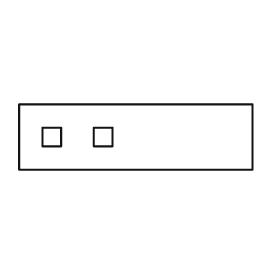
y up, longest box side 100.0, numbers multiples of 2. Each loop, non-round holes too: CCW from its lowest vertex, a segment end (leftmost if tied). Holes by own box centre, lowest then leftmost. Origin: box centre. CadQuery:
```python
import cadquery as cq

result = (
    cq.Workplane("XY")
    .moveTo(-50.0, -14.0)
    .lineTo(50.0, -14.0)
    .lineTo(50.0, 14.0)
    .lineTo(-50.0, 14.0)
    .close()
    .moveTo(-40.0, -4.0)
    .lineTo(-32.0, -4.0)
    .lineTo(-32.0, 4.0)
    .lineTo(-40.0, 4.0)
    .close()
    .moveTo(-18.0, -4.0)
    .lineTo(-10.0, -4.0)
    .lineTo(-10.0, 4.0)
    .lineTo(-18.0, 4.0)
    .close()
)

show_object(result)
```